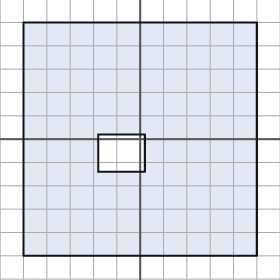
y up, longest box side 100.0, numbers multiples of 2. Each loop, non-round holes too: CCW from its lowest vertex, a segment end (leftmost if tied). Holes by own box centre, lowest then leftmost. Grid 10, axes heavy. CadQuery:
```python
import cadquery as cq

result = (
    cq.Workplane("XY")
    .moveTo(-50.0, -50.0)
    .lineTo(50.0, -50.0)
    .lineTo(50.0, 50.0)
    .lineTo(-50.0, 50.0)
    .close()
    .moveTo(-18.0, -14.0)
    .lineTo(2.0, -14.0)
    .lineTo(2.0, 2.0)
    .lineTo(-18.0, 2.0)
    .close()
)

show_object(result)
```